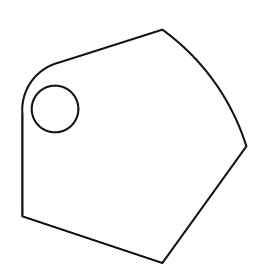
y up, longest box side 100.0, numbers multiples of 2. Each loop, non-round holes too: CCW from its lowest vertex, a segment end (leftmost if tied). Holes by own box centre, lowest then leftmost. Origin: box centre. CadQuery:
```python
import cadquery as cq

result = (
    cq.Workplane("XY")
    .moveTo(12.0, -50.0)
    .lineTo(48.0, 0.0)
    .threePointArc((34.0, 28.0), (12.0, 50.0))
    .lineTo(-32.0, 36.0)
    .threePointArc((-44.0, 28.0), (-48.0, 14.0))
    .lineTo(-48.0, -30.0)
    .close()
    .moveTo(-34.0, 16.0)
    .circle(10.0)
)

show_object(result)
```